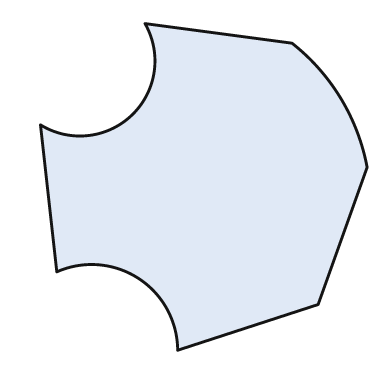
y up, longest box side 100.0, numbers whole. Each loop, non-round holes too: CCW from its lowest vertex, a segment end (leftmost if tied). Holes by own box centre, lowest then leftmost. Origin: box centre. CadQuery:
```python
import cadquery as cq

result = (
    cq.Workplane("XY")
    .moveTo(-8.0, -50.0)
    .lineTo(35.0, -36.0)
    .lineTo(50.0, 6.0)
    .threePointArc((42.0, 27.0), (27.0, 44.0))
    .lineTo(-18.0, 50.0)
    .threePointArc((-22.0, 22.0), (-50.0, 19.0))
    .lineTo(-45.0, -26.0)
    .threePointArc((-20.0, -28.0), (-8.0, -50.0))
    .close()
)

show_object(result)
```